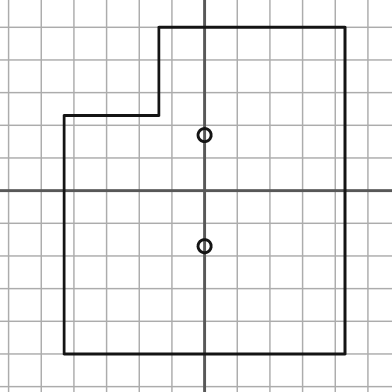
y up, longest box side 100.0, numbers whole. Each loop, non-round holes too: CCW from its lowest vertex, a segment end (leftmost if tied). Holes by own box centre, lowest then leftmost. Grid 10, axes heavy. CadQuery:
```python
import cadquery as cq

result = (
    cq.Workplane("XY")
    .moveTo(-43.0, -50.0)
    .lineTo(43.0, -50.0)
    .lineTo(43.0, 50.0)
    .lineTo(-14.0, 50.0)
    .lineTo(-14.0, 23.0)
    .lineTo(-43.0, 23.0)
    .close()
    .moveTo(0.0, -17.0)
    .circle(2.0)
    .moveTo(0.0, 17.0)
    .circle(2.0)
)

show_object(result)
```